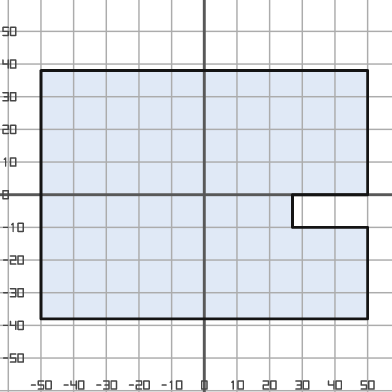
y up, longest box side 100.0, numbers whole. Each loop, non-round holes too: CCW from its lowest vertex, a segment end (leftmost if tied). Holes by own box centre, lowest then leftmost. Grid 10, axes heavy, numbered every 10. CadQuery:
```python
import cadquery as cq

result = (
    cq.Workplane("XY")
    .moveTo(-50.0, -38.0)
    .lineTo(50.0, -38.0)
    .lineTo(50.0, -10.0)
    .lineTo(27.0, -10.0)
    .lineTo(27.0, 0.0)
    .lineTo(50.0, 0.0)
    .lineTo(50.0, 38.0)
    .lineTo(-50.0, 38.0)
    .close()
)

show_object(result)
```